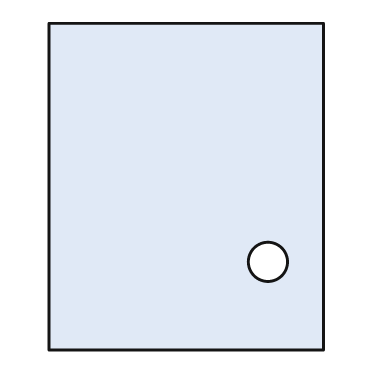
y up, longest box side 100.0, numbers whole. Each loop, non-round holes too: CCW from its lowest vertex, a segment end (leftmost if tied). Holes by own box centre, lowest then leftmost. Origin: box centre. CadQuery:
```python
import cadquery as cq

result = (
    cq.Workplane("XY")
    .moveTo(-42.0, -50.0)
    .lineTo(42.0, -50.0)
    .lineTo(42.0, 50.0)
    .lineTo(-42.0, 50.0)
    .close()
    .moveTo(25.0, -23.0)
    .circle(6.0)
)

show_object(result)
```